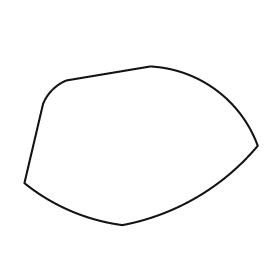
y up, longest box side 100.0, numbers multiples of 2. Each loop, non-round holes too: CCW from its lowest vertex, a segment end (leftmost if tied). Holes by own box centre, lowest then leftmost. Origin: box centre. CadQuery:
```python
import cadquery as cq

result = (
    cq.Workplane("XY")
    .moveTo(-8.0, -34.0)
    .threePointArc((24.0, -22.0), (50.0, 0.0))
    .threePointArc((32.0, 24.0), (4.0, 34.0))
    .lineTo(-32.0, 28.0)
    .threePointArc((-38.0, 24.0), (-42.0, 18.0))
    .lineTo(-50.0, -16.0)
    .threePointArc((-30.0, -28.0), (-8.0, -34.0))
    .close()
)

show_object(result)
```